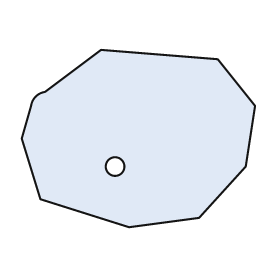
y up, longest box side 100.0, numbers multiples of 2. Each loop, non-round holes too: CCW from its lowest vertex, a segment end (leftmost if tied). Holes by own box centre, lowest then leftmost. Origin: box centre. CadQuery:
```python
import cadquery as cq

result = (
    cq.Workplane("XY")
    .moveTo(-4.0, -38.0)
    .lineTo(26.0, -34.0)
    .lineTo(46.0, -12.0)
    .lineTo(50.0, 14.0)
    .lineTo(34.0, 34.0)
    .lineTo(-16.0, 38.0)
    .lineTo(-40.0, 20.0)
    .threePointArc((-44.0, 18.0), (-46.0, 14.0))
    .lineTo(-50.0, 0.0)
    .lineTo(-42.0, -26.0)
    .close()
    .moveTo(-10.0, -12.0)
    .circle(4.0)
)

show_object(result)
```